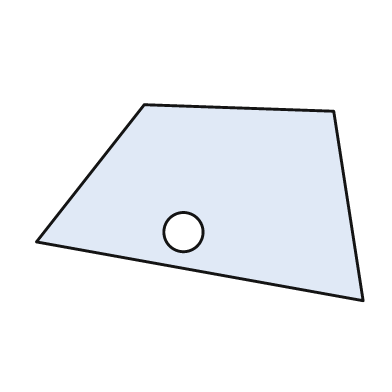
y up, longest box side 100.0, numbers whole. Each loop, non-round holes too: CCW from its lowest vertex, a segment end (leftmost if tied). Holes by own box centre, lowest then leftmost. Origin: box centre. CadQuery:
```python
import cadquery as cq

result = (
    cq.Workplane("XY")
    .moveTo(50.0, -30.0)
    .lineTo(41.0, 28.0)
    .lineTo(-17.0, 30.0)
    .lineTo(-50.0, -12.0)
    .close()
    .moveTo(-5.0, -9.0)
    .circle(6.0)
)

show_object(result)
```